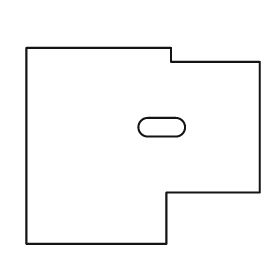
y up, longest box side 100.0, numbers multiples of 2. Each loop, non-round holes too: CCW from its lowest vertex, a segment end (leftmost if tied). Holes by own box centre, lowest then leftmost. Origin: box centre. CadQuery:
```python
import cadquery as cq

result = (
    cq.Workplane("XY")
    .moveTo(-50.0, -42.0)
    .lineTo(10.0, -42.0)
    .lineTo(10.0, -20.0)
    .lineTo(50.0, -20.0)
    .lineTo(50.0, 36.0)
    .lineTo(12.0, 36.0)
    .lineTo(12.0, 42.0)
    .lineTo(-50.0, 42.0)
    .close()
    .moveTo(2.0, 4.0)
    .lineTo(14.0, 4.0)
    .threePointArc((18.0, 8.0), (14.0, 12.0))
    .lineTo(2.0, 12.0)
    .threePointArc((-2.0, 8.0), (2.0, 4.0))
    .close()
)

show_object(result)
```